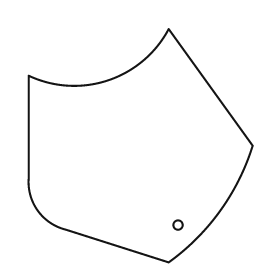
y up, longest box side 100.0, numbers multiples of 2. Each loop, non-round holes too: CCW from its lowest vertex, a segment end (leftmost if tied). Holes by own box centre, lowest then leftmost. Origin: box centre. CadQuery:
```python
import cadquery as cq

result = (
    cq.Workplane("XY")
    .moveTo(12.0, -50.0)
    .threePointArc((34.0, -28.0), (48.0, 0.0))
    .lineTo(12.0, 50.0)
    .threePointArc((-14.0, 28.0), (-48.0, 30.0))
    .lineTo(-48.0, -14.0)
    .threePointArc((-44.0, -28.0), (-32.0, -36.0))
    .close()
    .moveTo(16.0, -34.0)
    .circle(2.0)
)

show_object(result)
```